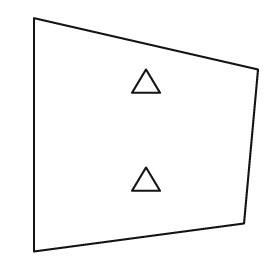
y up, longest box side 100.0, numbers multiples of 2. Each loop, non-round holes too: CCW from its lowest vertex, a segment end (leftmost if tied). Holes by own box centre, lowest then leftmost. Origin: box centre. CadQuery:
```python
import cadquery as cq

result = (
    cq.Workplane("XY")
    .moveTo(-48.0, -50.0)
    .lineTo(42.0, -38.0)
    .lineTo(48.0, 28.0)
    .lineTo(-48.0, 50.0)
    .close()
    .moveTo(-6.0, -24.0)
    .lineTo(6.0, -24.0)
    .lineTo(0.0, -14.0)
    .close()
    .moveTo(-6.0, 18.0)
    .lineTo(6.0, 18.0)
    .lineTo(0.0, 28.0)
    .close()
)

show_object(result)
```